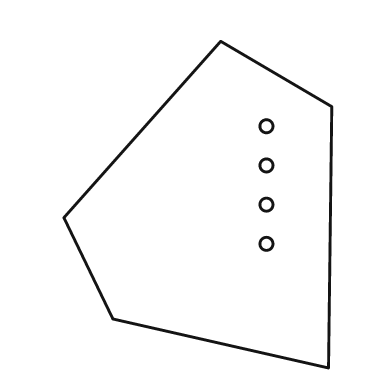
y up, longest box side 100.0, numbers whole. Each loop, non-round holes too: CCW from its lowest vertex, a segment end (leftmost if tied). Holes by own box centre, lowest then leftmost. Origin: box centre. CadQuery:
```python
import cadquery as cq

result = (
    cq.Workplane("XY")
    .moveTo(40.0, -50.0)
    .lineTo(41.0, 30.0)
    .lineTo(7.0, 50.0)
    .lineTo(-41.0, -4.0)
    .lineTo(-26.0, -35.0)
    .close()
    .moveTo(21.0, -12.0)
    .circle(2.0)
    .moveTo(21.0, 0.0)
    .circle(2.0)
    .moveTo(21.0, 12.0)
    .circle(2.0)
    .moveTo(21.0, 24.0)
    .circle(2.0)
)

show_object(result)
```